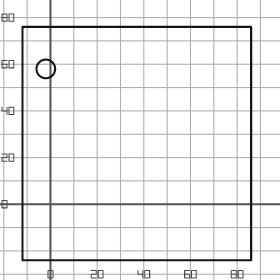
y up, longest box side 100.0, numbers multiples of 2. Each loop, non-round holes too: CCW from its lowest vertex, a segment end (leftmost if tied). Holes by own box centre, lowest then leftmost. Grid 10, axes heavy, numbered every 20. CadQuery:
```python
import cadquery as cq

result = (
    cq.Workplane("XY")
    .moveTo(-12.0, -24.0)
    .lineTo(86.0, -24.0)
    .lineTo(86.0, 76.0)
    .lineTo(-12.0, 76.0)
    .close()
    .moveTo(-2.0, 58.0)
    .circle(4.0)
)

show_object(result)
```